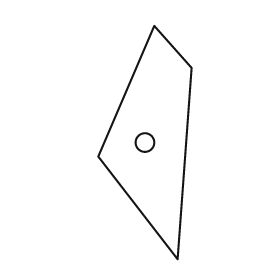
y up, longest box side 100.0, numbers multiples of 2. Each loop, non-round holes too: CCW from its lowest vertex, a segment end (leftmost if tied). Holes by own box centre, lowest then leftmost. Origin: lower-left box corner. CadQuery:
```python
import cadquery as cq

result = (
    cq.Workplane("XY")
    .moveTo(34.0, 0.0)
    .lineTo(40.0, 82.0)
    .lineTo(24.0, 100.0)
    .lineTo(0.0, 44.0)
    .close()
    .moveTo(20.0, 50.0)
    .circle(4.0)
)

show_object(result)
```